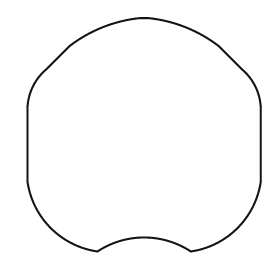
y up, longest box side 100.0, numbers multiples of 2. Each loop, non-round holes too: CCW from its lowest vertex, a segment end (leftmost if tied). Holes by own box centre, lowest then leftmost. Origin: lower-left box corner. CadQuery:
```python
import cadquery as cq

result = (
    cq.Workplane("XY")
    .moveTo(30.0, 0.0)
    .threePointArc((50.0, 6.0), (70.0, 0.0))
    .threePointArc((90.0, 10.0), (100.0, 30.0))
    .lineTo(100.0, 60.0)
    .threePointArc((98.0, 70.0), (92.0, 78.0))
    .lineTo(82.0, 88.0)
    .threePointArc((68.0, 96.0), (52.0, 100.0))
    .lineTo(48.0, 100.0)
    .threePointArc((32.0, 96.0), (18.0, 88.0))
    .lineTo(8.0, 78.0)
    .threePointArc((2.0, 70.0), (0.0, 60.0))
    .lineTo(0.0, 30.0)
    .threePointArc((10.0, 10.0), (30.0, 0.0))
    .close()
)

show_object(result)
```